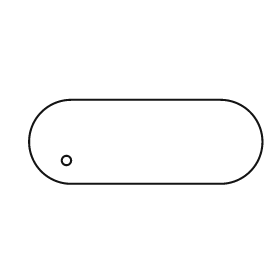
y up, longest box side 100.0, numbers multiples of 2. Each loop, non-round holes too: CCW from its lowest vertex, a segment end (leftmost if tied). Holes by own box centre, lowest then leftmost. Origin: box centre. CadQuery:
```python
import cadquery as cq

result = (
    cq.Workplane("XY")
    .moveTo(-32.0, -18.0)
    .lineTo(32.0, -18.0)
    .threePointArc((50.0, 0.0), (32.0, 18.0))
    .lineTo(-32.0, 18.0)
    .threePointArc((-50.0, 0.0), (-32.0, -18.0))
    .close()
    .moveTo(-34.0, -8.0)
    .circle(2.0)
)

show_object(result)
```